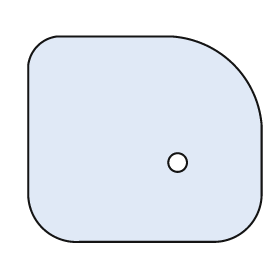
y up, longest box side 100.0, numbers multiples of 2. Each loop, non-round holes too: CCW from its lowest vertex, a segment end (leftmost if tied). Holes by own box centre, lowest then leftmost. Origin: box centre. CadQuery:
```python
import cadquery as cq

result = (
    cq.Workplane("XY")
    .moveTo(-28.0, -44.0)
    .lineTo(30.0, -44.0)
    .threePointArc((44.0, -38.0), (50.0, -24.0))
    .lineTo(50.0, 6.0)
    .threePointArc((38.0, 32.0), (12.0, 44.0))
    .lineTo(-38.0, 44.0)
    .threePointArc((-46.0, 40.0), (-50.0, 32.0))
    .lineTo(-50.0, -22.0)
    .threePointArc((-44.0, -38.0), (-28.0, -44.0))
    .close()
    .moveTo(14.0, -10.0)
    .circle(4.0)
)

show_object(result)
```